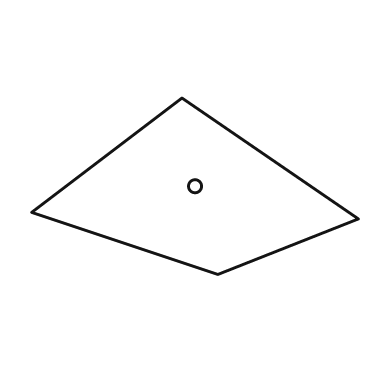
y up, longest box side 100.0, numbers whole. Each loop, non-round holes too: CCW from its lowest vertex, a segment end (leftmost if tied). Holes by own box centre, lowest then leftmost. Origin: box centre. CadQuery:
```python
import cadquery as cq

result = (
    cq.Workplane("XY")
    .moveTo(7.0, -27.0)
    .lineTo(50.0, -10.0)
    .lineTo(-4.0, 27.0)
    .lineTo(-50.0, -8.0)
    .close()
    .moveTo(0.0, 0.0)
    .circle(2.0)
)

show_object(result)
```